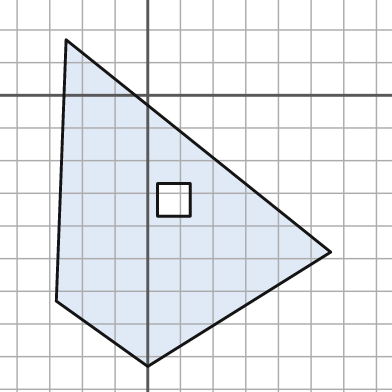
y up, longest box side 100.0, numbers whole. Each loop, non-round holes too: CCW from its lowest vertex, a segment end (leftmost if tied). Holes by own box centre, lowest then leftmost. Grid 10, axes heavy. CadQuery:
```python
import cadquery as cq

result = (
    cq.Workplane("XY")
    .moveTo(0.0, -83.0)
    .lineTo(56.0, -48.0)
    .lineTo(-25.0, 17.0)
    .lineTo(-28.0, -63.0)
    .close()
    .moveTo(3.0, -37.0)
    .lineTo(13.0, -37.0)
    .lineTo(13.0, -27.0)
    .lineTo(3.0, -27.0)
    .close()
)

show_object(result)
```